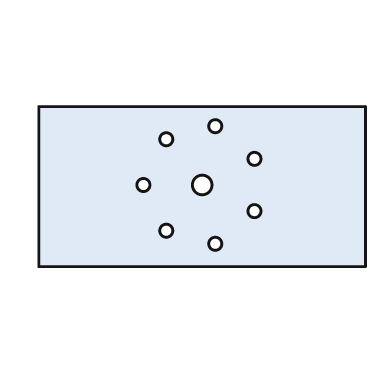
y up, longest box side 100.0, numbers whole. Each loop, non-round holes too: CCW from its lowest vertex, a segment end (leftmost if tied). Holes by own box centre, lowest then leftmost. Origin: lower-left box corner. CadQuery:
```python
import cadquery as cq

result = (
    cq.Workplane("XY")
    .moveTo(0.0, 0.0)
    .lineTo(100.0, 0.0)
    .lineTo(100.0, 49.0)
    .lineTo(0.0, 49.0)
    .close()
    .moveTo(54.0, 7.0)
    .circle(2.0)
    .moveTo(39.0, 11.0)
    .circle(2.0)
    .moveTo(66.0, 17.0)
    .circle(2.0)
    .moveTo(32.0, 25.0)
    .circle(2.0)
    .moveTo(50.0, 25.0)
    .circle(3.0)
    .moveTo(66.0, 33.0)
    .circle(2.0)
    .moveTo(39.0, 39.0)
    .circle(2.0)
    .moveTo(54.0, 43.0)
    .circle(2.0)
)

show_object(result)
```